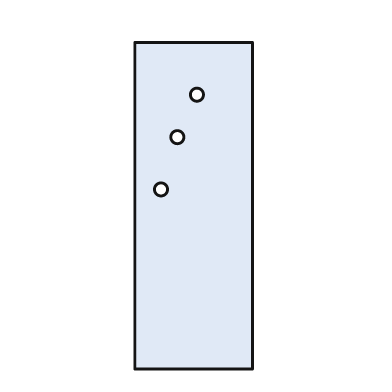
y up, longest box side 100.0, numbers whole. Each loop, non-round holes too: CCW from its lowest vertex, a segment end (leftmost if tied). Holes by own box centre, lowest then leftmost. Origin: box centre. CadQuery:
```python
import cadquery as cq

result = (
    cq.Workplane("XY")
    .moveTo(-18.0, -50.0)
    .lineTo(18.0, -50.0)
    .lineTo(18.0, 50.0)
    .lineTo(-18.0, 50.0)
    .close()
    .moveTo(-10.0, 5.0)
    .circle(2.0)
    .moveTo(-5.0, 21.0)
    .circle(2.0)
    .moveTo(1.0, 34.0)
    .circle(2.0)
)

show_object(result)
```